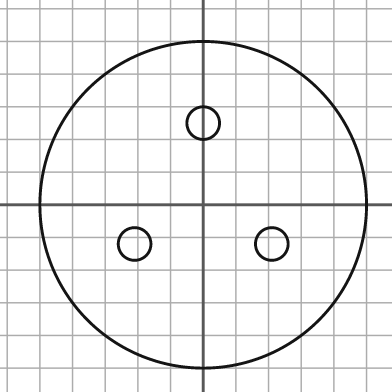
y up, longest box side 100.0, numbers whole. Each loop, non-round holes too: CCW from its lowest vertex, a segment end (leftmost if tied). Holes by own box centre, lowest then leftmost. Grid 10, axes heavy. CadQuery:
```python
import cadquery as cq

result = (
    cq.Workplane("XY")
    .moveTo(0.0, 0.0)
    .circle(50.0)
    .moveTo(-21.0, -12.0)
    .circle(5.0)
    .moveTo(21.0, -12.0)
    .circle(5.0)
    .moveTo(0.0, 25.0)
    .circle(5.0)
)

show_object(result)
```